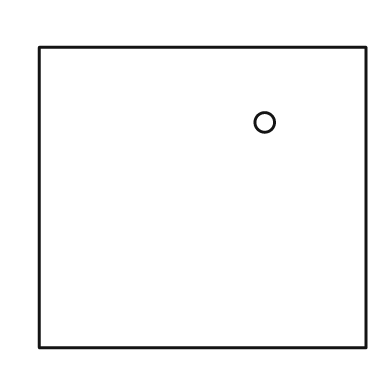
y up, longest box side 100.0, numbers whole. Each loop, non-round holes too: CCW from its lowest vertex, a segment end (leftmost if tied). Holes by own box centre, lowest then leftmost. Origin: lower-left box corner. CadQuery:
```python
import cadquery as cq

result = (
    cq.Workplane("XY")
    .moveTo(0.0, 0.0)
    .lineTo(100.0, 0.0)
    .lineTo(100.0, 92.0)
    .lineTo(0.0, 92.0)
    .close()
    .moveTo(69.0, 69.0)
    .circle(3.0)
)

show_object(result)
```